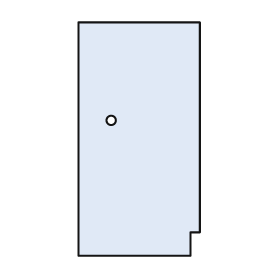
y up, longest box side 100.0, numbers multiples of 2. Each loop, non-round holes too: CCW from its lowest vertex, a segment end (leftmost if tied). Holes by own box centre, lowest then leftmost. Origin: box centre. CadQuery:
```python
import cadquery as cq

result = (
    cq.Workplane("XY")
    .moveTo(-26.0, -50.0)
    .lineTo(22.0, -50.0)
    .lineTo(22.0, -40.0)
    .lineTo(26.0, -40.0)
    .lineTo(26.0, 50.0)
    .lineTo(-26.0, 50.0)
    .close()
    .moveTo(-12.0, 8.0)
    .circle(2.0)
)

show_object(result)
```